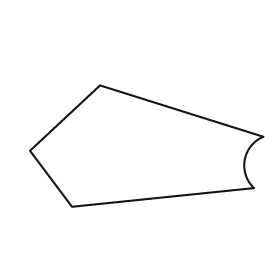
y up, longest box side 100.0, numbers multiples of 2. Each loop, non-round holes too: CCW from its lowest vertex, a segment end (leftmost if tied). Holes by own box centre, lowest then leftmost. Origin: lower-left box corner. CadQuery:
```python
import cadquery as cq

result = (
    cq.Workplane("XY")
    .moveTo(18.0, 0.0)
    .lineTo(96.0, 8.0)
    .threePointArc((92.0, 20.0), (100.0, 30.0))
    .lineTo(30.0, 52.0)
    .lineTo(0.0, 24.0)
    .close()
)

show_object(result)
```